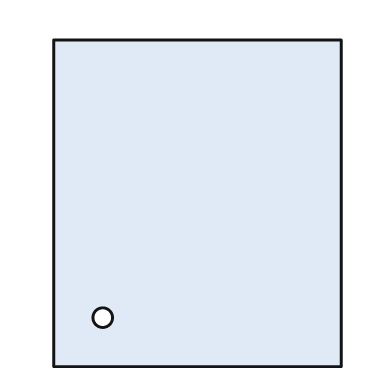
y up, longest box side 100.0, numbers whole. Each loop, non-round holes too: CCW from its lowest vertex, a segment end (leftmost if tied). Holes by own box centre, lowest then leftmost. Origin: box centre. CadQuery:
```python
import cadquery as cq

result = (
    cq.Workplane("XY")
    .moveTo(-44.0, -50.0)
    .lineTo(44.0, -50.0)
    .lineTo(44.0, 50.0)
    .lineTo(-44.0, 50.0)
    .close()
    .moveTo(-29.0, -35.0)
    .circle(3.0)
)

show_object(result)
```